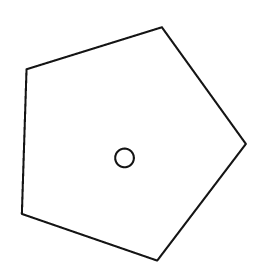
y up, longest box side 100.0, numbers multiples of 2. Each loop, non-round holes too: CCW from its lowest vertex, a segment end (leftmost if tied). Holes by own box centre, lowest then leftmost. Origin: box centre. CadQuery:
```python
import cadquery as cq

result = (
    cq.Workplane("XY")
    .moveTo(10.0, -50.0)
    .lineTo(48.0, 0.0)
    .lineTo(12.0, 50.0)
    .lineTo(-46.0, 32.0)
    .lineTo(-48.0, -30.0)
    .close()
    .moveTo(-4.0, -6.0)
    .circle(4.0)
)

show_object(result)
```